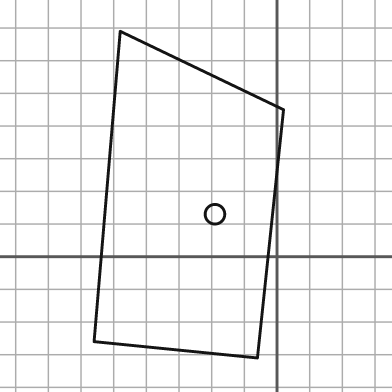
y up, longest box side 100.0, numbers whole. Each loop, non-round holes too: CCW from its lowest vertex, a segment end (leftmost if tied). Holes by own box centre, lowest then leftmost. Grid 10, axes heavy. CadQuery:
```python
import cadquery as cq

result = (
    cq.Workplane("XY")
    .moveTo(-6.0, -31.0)
    .lineTo(2.0, 45.0)
    .lineTo(-48.0, 69.0)
    .lineTo(-56.0, -26.0)
    .close()
    .moveTo(-19.0, 13.0)
    .circle(3.0)
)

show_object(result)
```